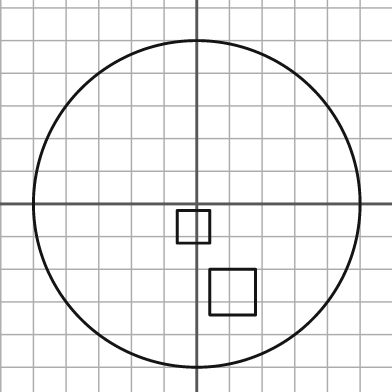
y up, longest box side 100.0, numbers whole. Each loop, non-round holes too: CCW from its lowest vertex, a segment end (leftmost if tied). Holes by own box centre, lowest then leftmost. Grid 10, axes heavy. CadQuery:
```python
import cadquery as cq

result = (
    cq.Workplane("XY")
    .moveTo(0.0, 0.0)
    .circle(50.0)
    .moveTo(4.0, -34.0)
    .lineTo(18.0, -34.0)
    .lineTo(18.0, -20.0)
    .lineTo(4.0, -20.0)
    .close()
    .moveTo(-6.0, -12.0)
    .lineTo(4.0, -12.0)
    .lineTo(4.0, -2.0)
    .lineTo(-6.0, -2.0)
    .close()
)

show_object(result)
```